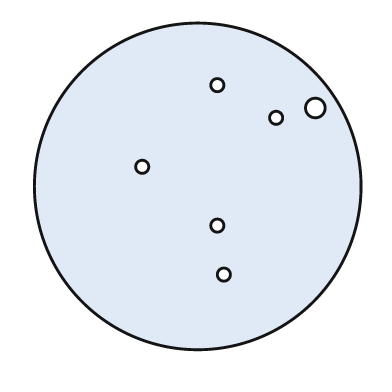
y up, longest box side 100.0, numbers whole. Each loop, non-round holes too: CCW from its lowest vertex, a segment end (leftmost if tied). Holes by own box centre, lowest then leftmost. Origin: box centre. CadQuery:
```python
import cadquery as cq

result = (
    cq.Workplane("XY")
    .moveTo(0.0, 0.0)
    .circle(50.0)
    .moveTo(8.0, -27.0)
    .circle(2.0)
    .moveTo(6.0, -12.0)
    .circle(2.0)
    .moveTo(-17.0, 6.0)
    .circle(2.0)
    .moveTo(24.0, 21.0)
    .circle(2.0)
    .moveTo(36.0, 24.0)
    .circle(3.0)
    .moveTo(6.0, 31.0)
    .circle(2.0)
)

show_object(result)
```